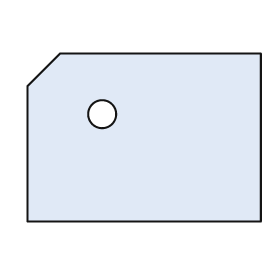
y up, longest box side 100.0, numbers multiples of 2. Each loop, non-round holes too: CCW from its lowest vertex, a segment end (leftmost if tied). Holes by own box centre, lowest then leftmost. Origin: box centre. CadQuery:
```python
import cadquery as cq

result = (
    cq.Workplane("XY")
    .moveTo(-50.0, -36.0)
    .lineTo(50.0, -36.0)
    .lineTo(50.0, 36.0)
    .lineTo(-36.0, 36.0)
    .lineTo(-50.0, 22.0)
    .close()
    .moveTo(-18.0, 10.0)
    .circle(6.0)
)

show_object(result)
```